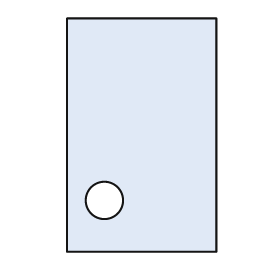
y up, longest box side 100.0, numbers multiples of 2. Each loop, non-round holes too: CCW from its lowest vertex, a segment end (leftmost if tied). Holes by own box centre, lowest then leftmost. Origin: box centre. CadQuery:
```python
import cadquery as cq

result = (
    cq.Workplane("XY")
    .moveTo(-32.0, -50.0)
    .lineTo(32.0, -50.0)
    .lineTo(32.0, 50.0)
    .lineTo(-32.0, 50.0)
    .close()
    .moveTo(-16.0, -28.0)
    .circle(8.0)
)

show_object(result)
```